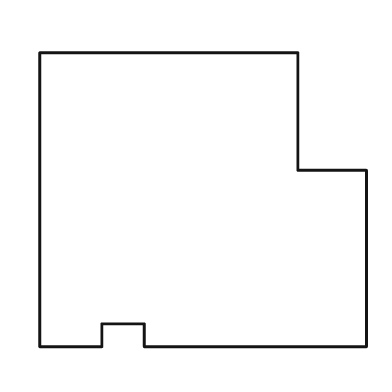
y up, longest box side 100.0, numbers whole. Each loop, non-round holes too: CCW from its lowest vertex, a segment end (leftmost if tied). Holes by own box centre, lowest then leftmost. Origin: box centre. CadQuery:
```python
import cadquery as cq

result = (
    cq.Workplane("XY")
    .moveTo(-50.0, -45.0)
    .lineTo(-31.0, -45.0)
    .lineTo(-31.0, -38.0)
    .lineTo(-18.0, -38.0)
    .lineTo(-18.0, -45.0)
    .lineTo(50.0, -45.0)
    .lineTo(50.0, 9.0)
    .lineTo(29.0, 9.0)
    .lineTo(29.0, 45.0)
    .lineTo(-50.0, 45.0)
    .close()
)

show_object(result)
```